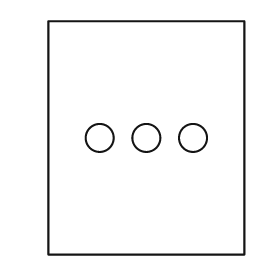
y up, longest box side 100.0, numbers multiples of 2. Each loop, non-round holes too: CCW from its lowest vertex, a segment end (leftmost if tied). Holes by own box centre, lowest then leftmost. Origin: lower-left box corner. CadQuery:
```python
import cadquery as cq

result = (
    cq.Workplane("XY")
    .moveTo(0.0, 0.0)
    .lineTo(84.0, 0.0)
    .lineTo(84.0, 100.0)
    .lineTo(0.0, 100.0)
    .close()
    .moveTo(22.0, 50.0)
    .circle(6.0)
    .moveTo(42.0, 50.0)
    .circle(6.0)
    .moveTo(62.0, 50.0)
    .circle(6.0)
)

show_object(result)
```